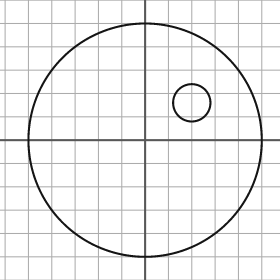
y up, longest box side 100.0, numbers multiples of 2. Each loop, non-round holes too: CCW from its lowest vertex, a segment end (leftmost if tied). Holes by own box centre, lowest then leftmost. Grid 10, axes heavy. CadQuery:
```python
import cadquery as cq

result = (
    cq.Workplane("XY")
    .moveTo(0.0, 0.0)
    .circle(50.0)
    .moveTo(20.0, 16.0)
    .circle(8.0)
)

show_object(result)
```